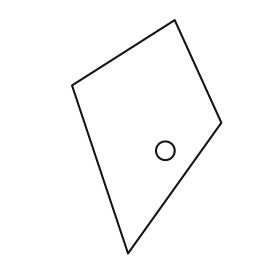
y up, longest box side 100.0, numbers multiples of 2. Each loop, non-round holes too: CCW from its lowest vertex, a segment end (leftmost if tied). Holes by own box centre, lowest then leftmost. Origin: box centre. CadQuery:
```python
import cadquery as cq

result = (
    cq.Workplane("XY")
    .moveTo(-8.0, -50.0)
    .lineTo(32.0, 6.0)
    .lineTo(12.0, 50.0)
    .lineTo(-32.0, 22.0)
    .close()
    .moveTo(8.0, -6.0)
    .circle(4.0)
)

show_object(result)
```